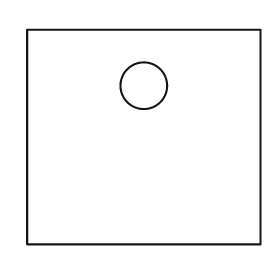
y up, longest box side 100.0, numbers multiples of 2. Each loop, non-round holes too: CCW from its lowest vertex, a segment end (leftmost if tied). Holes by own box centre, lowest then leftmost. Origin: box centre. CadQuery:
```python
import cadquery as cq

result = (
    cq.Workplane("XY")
    .moveTo(-50.0, -46.0)
    .lineTo(50.0, -46.0)
    .lineTo(50.0, 46.0)
    .lineTo(-50.0, 46.0)
    .close()
    .moveTo(0.0, 22.0)
    .circle(10.0)
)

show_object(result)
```